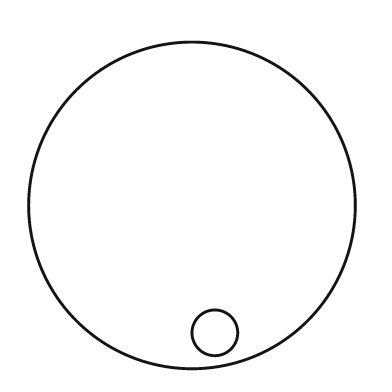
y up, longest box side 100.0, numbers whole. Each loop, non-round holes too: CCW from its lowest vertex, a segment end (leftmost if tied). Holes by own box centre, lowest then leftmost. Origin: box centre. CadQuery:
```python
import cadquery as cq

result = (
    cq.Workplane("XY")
    .moveTo(0.0, 0.0)
    .circle(50.0)
    .moveTo(7.0, -39.0)
    .circle(7.0)
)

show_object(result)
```